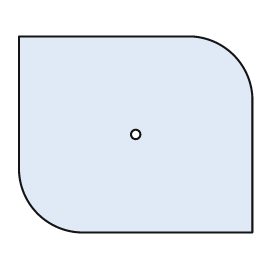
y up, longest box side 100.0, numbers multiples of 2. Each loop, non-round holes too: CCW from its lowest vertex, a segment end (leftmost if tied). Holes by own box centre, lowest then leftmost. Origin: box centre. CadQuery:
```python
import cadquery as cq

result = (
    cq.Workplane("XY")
    .moveTo(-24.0, -42.0)
    .lineTo(50.0, -42.0)
    .lineTo(50.0, 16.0)
    .threePointArc((42.0, 34.0), (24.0, 42.0))
    .lineTo(-50.0, 42.0)
    .lineTo(-50.0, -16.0)
    .threePointArc((-42.0, -34.0), (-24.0, -42.0))
    .close()
    .moveTo(0.0, 0.0)
    .circle(2.0)
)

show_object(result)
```